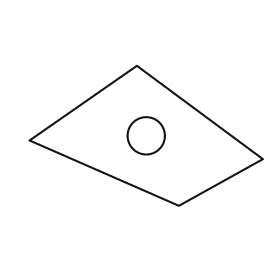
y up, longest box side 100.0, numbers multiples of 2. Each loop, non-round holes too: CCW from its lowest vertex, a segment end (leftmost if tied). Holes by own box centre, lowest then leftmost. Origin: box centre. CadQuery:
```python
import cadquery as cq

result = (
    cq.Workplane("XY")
    .moveTo(14.0, -30.0)
    .lineTo(50.0, -10.0)
    .lineTo(-4.0, 30.0)
    .lineTo(-50.0, -2.0)
    .close()
    .moveTo(0.0, 0.0)
    .circle(8.0)
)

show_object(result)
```